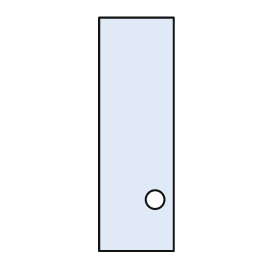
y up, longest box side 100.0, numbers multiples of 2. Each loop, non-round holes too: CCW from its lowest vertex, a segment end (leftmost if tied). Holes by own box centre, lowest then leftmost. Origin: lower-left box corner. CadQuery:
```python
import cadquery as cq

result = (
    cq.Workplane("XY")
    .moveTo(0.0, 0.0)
    .lineTo(32.0, 0.0)
    .lineTo(32.0, 100.0)
    .lineTo(0.0, 100.0)
    .close()
    .moveTo(24.0, 22.0)
    .circle(4.0)
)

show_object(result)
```